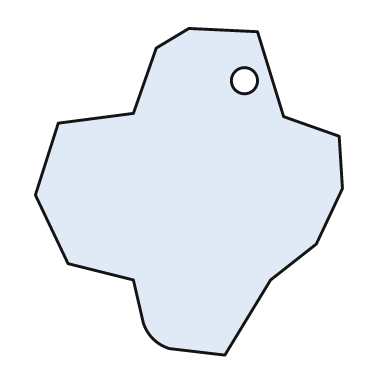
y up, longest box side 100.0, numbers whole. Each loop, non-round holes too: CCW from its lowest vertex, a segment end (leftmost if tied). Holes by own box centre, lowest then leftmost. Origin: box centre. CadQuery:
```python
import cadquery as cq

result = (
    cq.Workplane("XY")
    .moveTo(11.0, -50.0)
    .lineTo(25.0, -27.0)
    .lineTo(39.0, -16.0)
    .lineTo(47.0, 1.0)
    .lineTo(46.0, 17.0)
    .lineTo(29.0, 23.0)
    .lineTo(21.0, 49.0)
    .lineTo(0.0, 50.0)
    .lineTo(-10.0, 44.0)
    .lineTo(-17.0, 24.0)
    .lineTo(-40.0, 21.0)
    .lineTo(-47.0, -1.0)
    .lineTo(-37.0, -22.0)
    .lineTo(-17.0, -27.0)
    .lineTo(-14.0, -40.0)
    .threePointArc((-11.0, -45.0), (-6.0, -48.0))
    .close()
    .moveTo(17.0, 34.0)
    .circle(4.0)
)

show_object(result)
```